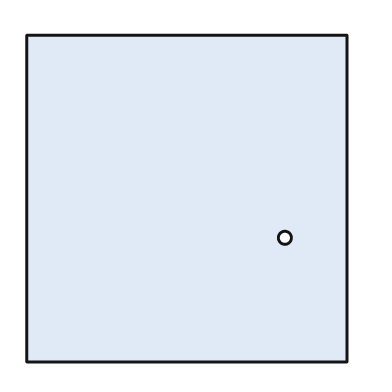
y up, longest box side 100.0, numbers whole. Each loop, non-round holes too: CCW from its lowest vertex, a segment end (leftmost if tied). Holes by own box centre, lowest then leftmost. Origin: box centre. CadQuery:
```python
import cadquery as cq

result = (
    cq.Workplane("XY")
    .moveTo(-49.0, -50.0)
    .lineTo(49.0, -50.0)
    .lineTo(49.0, 50.0)
    .lineTo(-49.0, 50.0)
    .close()
    .moveTo(30.0, -12.0)
    .circle(2.0)
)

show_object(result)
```